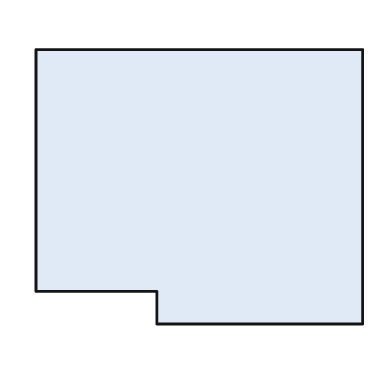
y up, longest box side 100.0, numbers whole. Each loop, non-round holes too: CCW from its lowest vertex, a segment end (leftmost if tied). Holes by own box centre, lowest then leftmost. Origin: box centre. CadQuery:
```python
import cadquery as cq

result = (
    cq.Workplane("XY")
    .moveTo(-13.0, -42.0)
    .lineTo(50.0, -42.0)
    .lineTo(50.0, 42.0)
    .lineTo(-50.0, 42.0)
    .lineTo(-50.0, -32.0)
    .lineTo(-13.0, -32.0)
    .close()
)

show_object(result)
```